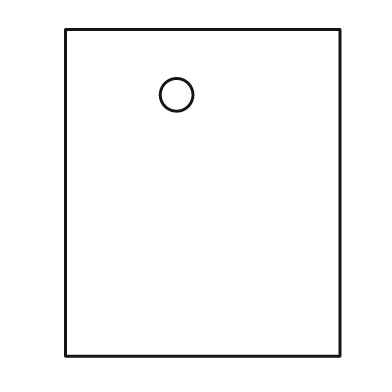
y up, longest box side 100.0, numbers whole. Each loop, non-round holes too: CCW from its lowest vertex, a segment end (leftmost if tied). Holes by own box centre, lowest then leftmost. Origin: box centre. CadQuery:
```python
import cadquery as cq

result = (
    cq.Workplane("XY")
    .moveTo(-42.0, -50.0)
    .lineTo(42.0, -50.0)
    .lineTo(42.0, 50.0)
    .lineTo(-42.0, 50.0)
    .close()
    .moveTo(-8.0, 30.0)
    .circle(5.0)
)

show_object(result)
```